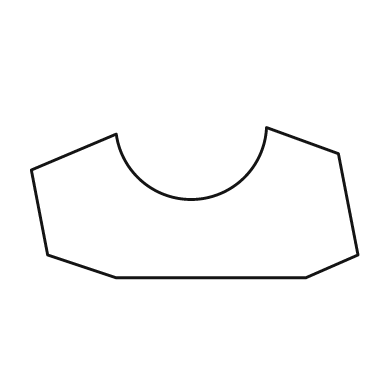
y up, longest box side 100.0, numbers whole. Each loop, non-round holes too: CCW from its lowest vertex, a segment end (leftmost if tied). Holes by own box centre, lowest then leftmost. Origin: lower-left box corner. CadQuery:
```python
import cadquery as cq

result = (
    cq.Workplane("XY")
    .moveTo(26.0, 0.0)
    .lineTo(84.0, 0.0)
    .lineTo(100.0, 7.0)
    .lineTo(94.0, 38.0)
    .lineTo(72.0, 46.0)
    .threePointArc((50.0, 24.0), (26.0, 44.0))
    .lineTo(0.0, 33.0)
    .lineTo(5.0, 7.0)
    .close()
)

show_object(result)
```